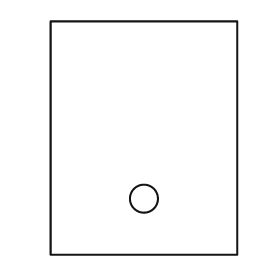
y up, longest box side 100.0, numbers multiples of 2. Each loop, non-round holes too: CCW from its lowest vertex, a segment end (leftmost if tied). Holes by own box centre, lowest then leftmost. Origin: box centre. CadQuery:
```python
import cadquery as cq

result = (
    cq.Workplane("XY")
    .moveTo(-40.0, -50.0)
    .lineTo(40.0, -50.0)
    .lineTo(40.0, 50.0)
    .lineTo(-40.0, 50.0)
    .close()
    .moveTo(0.0, -26.0)
    .circle(6.0)
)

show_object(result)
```